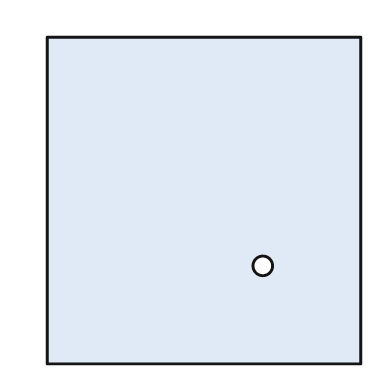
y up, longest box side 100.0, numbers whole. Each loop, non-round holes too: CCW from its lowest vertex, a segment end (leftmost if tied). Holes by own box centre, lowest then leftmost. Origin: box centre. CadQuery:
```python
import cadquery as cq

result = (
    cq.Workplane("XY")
    .moveTo(-48.0, -50.0)
    .lineTo(48.0, -50.0)
    .lineTo(48.0, 50.0)
    .lineTo(-48.0, 50.0)
    .close()
    .moveTo(18.0, -20.0)
    .circle(3.0)
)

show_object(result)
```